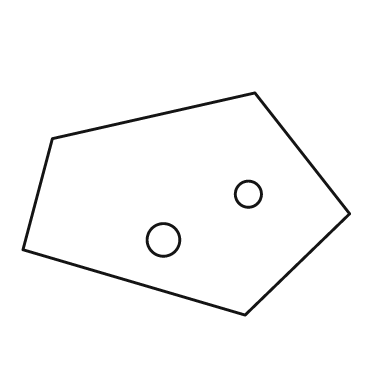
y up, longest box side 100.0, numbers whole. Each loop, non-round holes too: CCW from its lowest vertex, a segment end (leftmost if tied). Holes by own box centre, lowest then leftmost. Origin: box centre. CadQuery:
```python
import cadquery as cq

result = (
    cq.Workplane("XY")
    .moveTo(18.0, -34.0)
    .lineTo(50.0, -3.0)
    .lineTo(21.0, 34.0)
    .lineTo(-41.0, 20.0)
    .lineTo(-50.0, -14.0)
    .close()
    .moveTo(-7.0, -11.0)
    .circle(5.0)
    .moveTo(19.0, 3.0)
    .circle(4.0)
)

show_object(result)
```